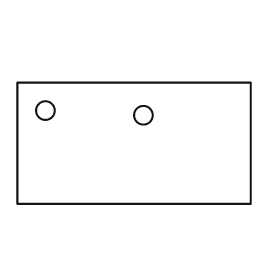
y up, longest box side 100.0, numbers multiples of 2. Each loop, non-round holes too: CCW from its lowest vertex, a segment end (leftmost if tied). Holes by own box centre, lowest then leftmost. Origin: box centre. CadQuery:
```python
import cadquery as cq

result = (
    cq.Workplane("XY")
    .moveTo(-50.0, -26.0)
    .lineTo(50.0, -26.0)
    .lineTo(50.0, 26.0)
    .lineTo(-50.0, 26.0)
    .close()
    .moveTo(4.0, 12.0)
    .circle(4.0)
    .moveTo(-38.0, 14.0)
    .circle(4.0)
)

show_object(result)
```